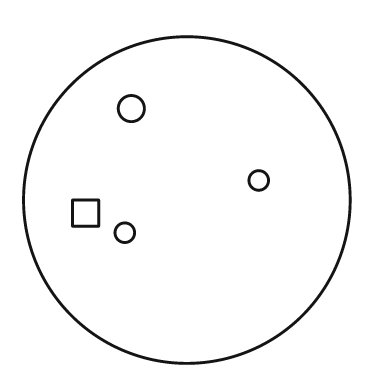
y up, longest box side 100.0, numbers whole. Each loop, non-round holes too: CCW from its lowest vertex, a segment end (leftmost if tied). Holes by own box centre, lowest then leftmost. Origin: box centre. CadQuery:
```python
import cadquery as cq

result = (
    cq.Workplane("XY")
    .moveTo(0.0, 0.0)
    .circle(50.0)
    .moveTo(-19.0, -10.0)
    .circle(3.0)
    .moveTo(-35.0, -8.0)
    .lineTo(-27.0, -8.0)
    .lineTo(-27.0, 0.0)
    .lineTo(-35.0, 0.0)
    .close()
    .moveTo(22.0, 6.0)
    .circle(3.0)
    .moveTo(-17.0, 28.0)
    .circle(4.0)
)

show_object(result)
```